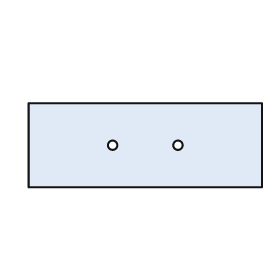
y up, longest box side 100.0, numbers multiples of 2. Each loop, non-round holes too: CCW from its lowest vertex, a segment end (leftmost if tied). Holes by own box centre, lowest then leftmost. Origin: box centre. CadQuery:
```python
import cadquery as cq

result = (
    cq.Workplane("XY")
    .moveTo(-50.0, -18.0)
    .lineTo(50.0, -18.0)
    .lineTo(50.0, 18.0)
    .lineTo(-50.0, 18.0)
    .close()
    .moveTo(-14.0, 0.0)
    .circle(2.0)
    .moveTo(14.0, 0.0)
    .circle(2.0)
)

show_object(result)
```